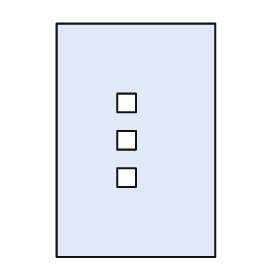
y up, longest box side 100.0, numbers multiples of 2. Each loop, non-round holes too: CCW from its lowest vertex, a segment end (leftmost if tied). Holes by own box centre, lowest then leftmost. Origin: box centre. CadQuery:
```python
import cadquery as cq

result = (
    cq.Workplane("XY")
    .moveTo(-34.0, -50.0)
    .lineTo(34.0, -50.0)
    .lineTo(34.0, 50.0)
    .lineTo(-34.0, 50.0)
    .close()
    .moveTo(-8.0, -20.0)
    .lineTo(0.0, -20.0)
    .lineTo(0.0, -12.0)
    .lineTo(-8.0, -12.0)
    .close()
    .moveTo(-8.0, -4.0)
    .lineTo(0.0, -4.0)
    .lineTo(0.0, 4.0)
    .lineTo(-8.0, 4.0)
    .close()
    .moveTo(-8.0, 12.0)
    .lineTo(0.0, 12.0)
    .lineTo(0.0, 20.0)
    .lineTo(-8.0, 20.0)
    .close()
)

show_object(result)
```